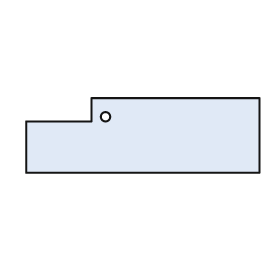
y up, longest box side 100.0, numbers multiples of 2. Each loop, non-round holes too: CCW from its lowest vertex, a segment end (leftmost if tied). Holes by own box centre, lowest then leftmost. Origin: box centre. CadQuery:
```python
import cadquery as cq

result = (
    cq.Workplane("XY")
    .moveTo(-50.0, -16.0)
    .lineTo(50.0, -16.0)
    .lineTo(50.0, 16.0)
    .lineTo(-22.0, 16.0)
    .lineTo(-22.0, 6.0)
    .lineTo(-50.0, 6.0)
    .close()
    .moveTo(-16.0, 8.0)
    .circle(2.0)
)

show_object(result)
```